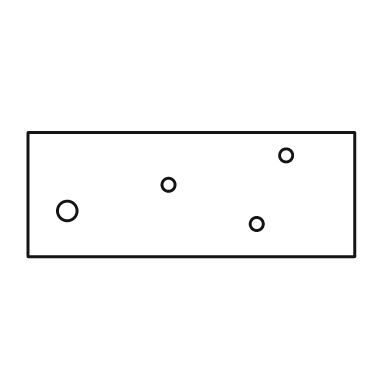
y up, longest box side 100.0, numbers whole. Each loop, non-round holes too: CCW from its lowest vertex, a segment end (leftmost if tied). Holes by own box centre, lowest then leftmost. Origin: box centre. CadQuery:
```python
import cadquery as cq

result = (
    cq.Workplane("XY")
    .moveTo(-50.0, -19.0)
    .lineTo(50.0, -19.0)
    .lineTo(50.0, 19.0)
    .lineTo(-50.0, 19.0)
    .close()
    .moveTo(20.0, -9.0)
    .circle(2.0)
    .moveTo(-38.0, -5.0)
    .circle(3.0)
    .moveTo(-7.0, 3.0)
    .circle(2.0)
    .moveTo(29.0, 12.0)
    .circle(2.0)
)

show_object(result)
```